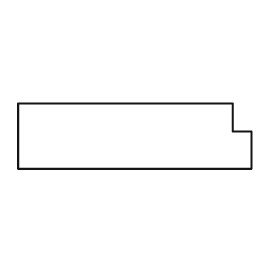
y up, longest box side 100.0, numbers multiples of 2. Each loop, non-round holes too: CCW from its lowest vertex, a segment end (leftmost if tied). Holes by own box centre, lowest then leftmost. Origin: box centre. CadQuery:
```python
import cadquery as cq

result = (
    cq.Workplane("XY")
    .moveTo(-50.0, -14.0)
    .lineTo(50.0, -14.0)
    .lineTo(50.0, 2.0)
    .lineTo(42.0, 2.0)
    .lineTo(42.0, 14.0)
    .lineTo(-50.0, 14.0)
    .close()
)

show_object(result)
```